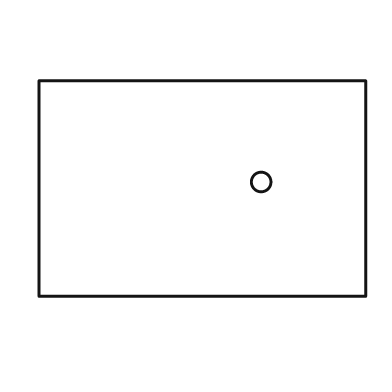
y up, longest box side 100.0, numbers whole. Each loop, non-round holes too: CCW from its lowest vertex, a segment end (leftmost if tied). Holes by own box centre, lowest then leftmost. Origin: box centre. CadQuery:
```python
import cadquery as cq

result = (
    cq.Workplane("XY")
    .moveTo(-50.0, -33.0)
    .lineTo(50.0, -33.0)
    .lineTo(50.0, 33.0)
    .lineTo(-50.0, 33.0)
    .close()
    .moveTo(18.0, 2.0)
    .circle(3.0)
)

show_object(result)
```